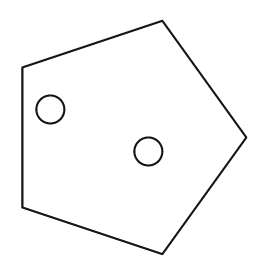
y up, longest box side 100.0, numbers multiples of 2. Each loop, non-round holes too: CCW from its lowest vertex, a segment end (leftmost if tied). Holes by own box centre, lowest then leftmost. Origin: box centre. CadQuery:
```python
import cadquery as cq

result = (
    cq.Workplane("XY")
    .moveTo(12.0, -50.0)
    .lineTo(48.0, 0.0)
    .lineTo(12.0, 50.0)
    .lineTo(-48.0, 30.0)
    .lineTo(-48.0, -30.0)
    .close()
    .moveTo(6.0, -6.0)
    .circle(6.0)
    .moveTo(-36.0, 12.0)
    .circle(6.0)
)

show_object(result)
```